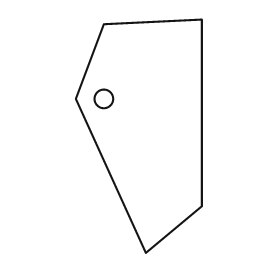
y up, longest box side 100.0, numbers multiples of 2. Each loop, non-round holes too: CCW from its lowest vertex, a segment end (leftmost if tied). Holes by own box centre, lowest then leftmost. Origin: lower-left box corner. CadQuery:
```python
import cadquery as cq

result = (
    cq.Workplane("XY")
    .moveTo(30.0, 0.0)
    .lineTo(54.0, 20.0)
    .lineTo(54.0, 100.0)
    .lineTo(12.0, 98.0)
    .lineTo(0.0, 66.0)
    .close()
    .moveTo(12.0, 66.0)
    .circle(4.0)
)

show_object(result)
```